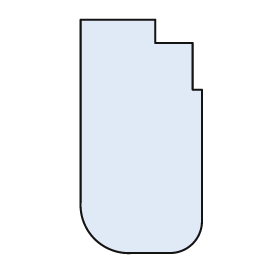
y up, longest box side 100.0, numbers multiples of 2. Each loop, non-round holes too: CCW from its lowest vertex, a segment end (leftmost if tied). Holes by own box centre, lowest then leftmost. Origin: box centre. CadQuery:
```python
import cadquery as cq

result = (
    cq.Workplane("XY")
    .moveTo(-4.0, -50.0)
    .lineTo(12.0, -50.0)
    .threePointArc((22.0, -46.0), (26.0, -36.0))
    .lineTo(26.0, 20.0)
    .lineTo(22.0, 20.0)
    .lineTo(22.0, 40.0)
    .lineTo(6.0, 40.0)
    .lineTo(6.0, 50.0)
    .lineTo(-26.0, 50.0)
    .lineTo(-26.0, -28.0)
    .threePointArc((-20.0, -44.0), (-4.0, -50.0))
    .close()
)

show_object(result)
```